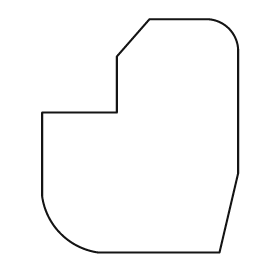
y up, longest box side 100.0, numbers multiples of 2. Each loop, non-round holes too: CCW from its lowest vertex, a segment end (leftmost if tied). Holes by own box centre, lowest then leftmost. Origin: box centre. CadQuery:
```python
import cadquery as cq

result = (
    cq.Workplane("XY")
    .moveTo(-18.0, -50.0)
    .lineTo(34.0, -50.0)
    .lineTo(42.0, -16.0)
    .lineTo(42.0, 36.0)
    .threePointArc((38.0, 46.0), (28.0, 50.0))
    .lineTo(4.0, 50.0)
    .lineTo(-10.0, 34.0)
    .lineTo(-10.0, 10.0)
    .lineTo(-42.0, 10.0)
    .lineTo(-42.0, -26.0)
    .threePointArc((-34.0, -42.0), (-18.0, -50.0))
    .close()
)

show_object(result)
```